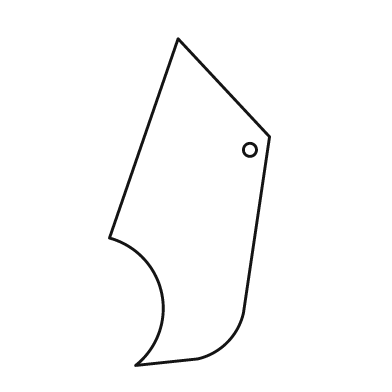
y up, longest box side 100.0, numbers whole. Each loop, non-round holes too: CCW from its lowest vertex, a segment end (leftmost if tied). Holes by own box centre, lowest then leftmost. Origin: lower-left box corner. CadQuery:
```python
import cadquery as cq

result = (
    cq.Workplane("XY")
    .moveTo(8.0, 0.0)
    .lineTo(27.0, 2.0)
    .threePointArc((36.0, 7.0), (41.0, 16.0))
    .lineTo(49.0, 70.0)
    .lineTo(21.0, 100.0)
    .lineTo(0.0, 39.0)
    .threePointArc((16.0, 22.0), (8.0, 0.0))
    .close()
    .moveTo(43.0, 66.0)
    .circle(2.0)
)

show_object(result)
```